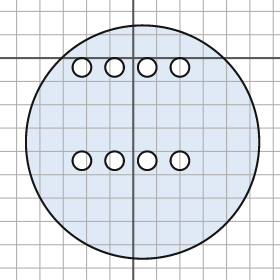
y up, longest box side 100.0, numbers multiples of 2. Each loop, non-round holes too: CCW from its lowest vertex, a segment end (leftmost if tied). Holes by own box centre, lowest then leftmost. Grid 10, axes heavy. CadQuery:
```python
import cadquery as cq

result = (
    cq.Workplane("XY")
    .moveTo(4.0, -36.0)
    .circle(50.0)
    .moveTo(-22.0, -44.0)
    .circle(4.0)
    .moveTo(-8.0, -44.0)
    .circle(4.0)
    .moveTo(6.0, -44.0)
    .circle(4.0)
    .moveTo(20.0, -44.0)
    .circle(4.0)
    .moveTo(-22.0, -4.0)
    .circle(4.0)
    .moveTo(-8.0, -4.0)
    .circle(4.0)
    .moveTo(6.0, -4.0)
    .circle(4.0)
    .moveTo(20.0, -4.0)
    .circle(4.0)
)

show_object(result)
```